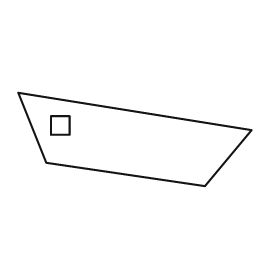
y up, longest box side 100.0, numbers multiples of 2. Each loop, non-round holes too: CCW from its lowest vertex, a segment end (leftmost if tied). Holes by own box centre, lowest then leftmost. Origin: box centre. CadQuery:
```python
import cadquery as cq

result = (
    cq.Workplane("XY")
    .moveTo(30.0, -20.0)
    .lineTo(50.0, 4.0)
    .lineTo(-50.0, 20.0)
    .lineTo(-38.0, -10.0)
    .close()
    .moveTo(-36.0, 2.0)
    .lineTo(-28.0, 2.0)
    .lineTo(-28.0, 10.0)
    .lineTo(-36.0, 10.0)
    .close()
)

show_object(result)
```